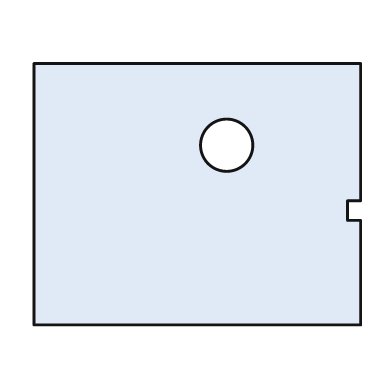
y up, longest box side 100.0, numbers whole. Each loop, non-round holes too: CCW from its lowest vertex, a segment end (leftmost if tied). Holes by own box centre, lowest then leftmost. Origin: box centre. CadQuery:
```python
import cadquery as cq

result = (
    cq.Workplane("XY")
    .moveTo(-50.0, -40.0)
    .lineTo(50.0, -40.0)
    .lineTo(50.0, -8.0)
    .lineTo(46.0, -8.0)
    .lineTo(46.0, -2.0)
    .lineTo(50.0, -2.0)
    .lineTo(50.0, 40.0)
    .lineTo(-50.0, 40.0)
    .close()
    .moveTo(9.0, 15.0)
    .circle(8.0)
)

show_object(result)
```